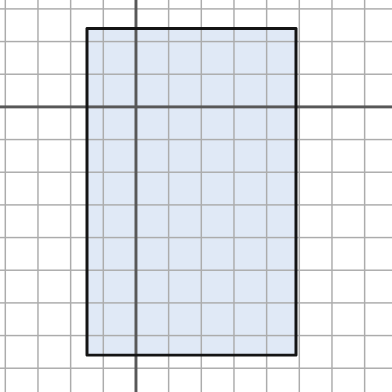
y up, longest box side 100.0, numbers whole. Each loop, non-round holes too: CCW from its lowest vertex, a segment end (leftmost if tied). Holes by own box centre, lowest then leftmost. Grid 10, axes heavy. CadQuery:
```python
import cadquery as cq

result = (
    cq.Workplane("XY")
    .moveTo(-15.0, -76.0)
    .lineTo(49.0, -76.0)
    .lineTo(49.0, 24.0)
    .lineTo(-15.0, 24.0)
    .close()
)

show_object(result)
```